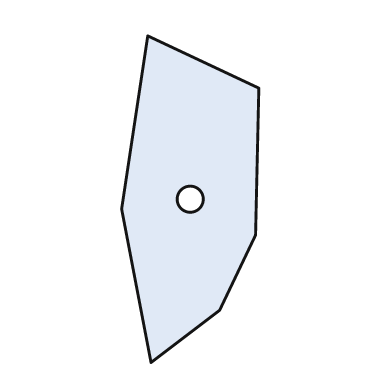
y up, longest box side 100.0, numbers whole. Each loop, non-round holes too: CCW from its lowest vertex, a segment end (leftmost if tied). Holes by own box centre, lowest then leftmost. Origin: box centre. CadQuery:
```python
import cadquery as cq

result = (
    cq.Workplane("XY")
    .moveTo(-12.0, -50.0)
    .lineTo(9.0, -34.0)
    .lineTo(20.0, -11.0)
    .lineTo(21.0, 34.0)
    .lineTo(-13.0, 50.0)
    .lineTo(-21.0, -3.0)
    .close()
    .moveTo(0.0, 0.0)
    .circle(4.0)
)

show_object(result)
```